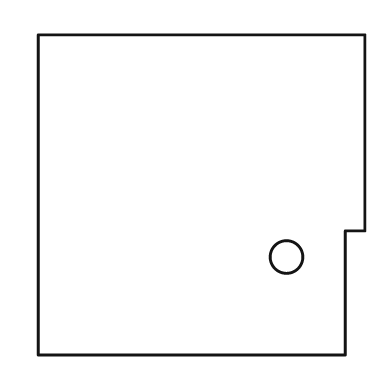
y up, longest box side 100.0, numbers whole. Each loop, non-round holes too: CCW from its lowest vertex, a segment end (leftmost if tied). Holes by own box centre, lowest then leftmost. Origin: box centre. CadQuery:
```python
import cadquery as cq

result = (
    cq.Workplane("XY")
    .moveTo(-50.0, -49.0)
    .lineTo(44.0, -49.0)
    .lineTo(44.0, -11.0)
    .lineTo(50.0, -11.0)
    .lineTo(50.0, 49.0)
    .lineTo(-50.0, 49.0)
    .close()
    .moveTo(26.0, -19.0)
    .circle(5.0)
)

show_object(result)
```